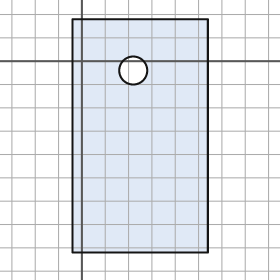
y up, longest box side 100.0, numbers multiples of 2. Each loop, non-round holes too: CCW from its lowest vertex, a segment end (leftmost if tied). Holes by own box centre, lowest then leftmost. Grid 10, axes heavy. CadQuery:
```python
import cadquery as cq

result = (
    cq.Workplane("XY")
    .moveTo(-4.0, -82.0)
    .lineTo(54.0, -82.0)
    .lineTo(54.0, 18.0)
    .lineTo(-4.0, 18.0)
    .close()
    .moveTo(22.0, -4.0)
    .circle(6.0)
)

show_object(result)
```